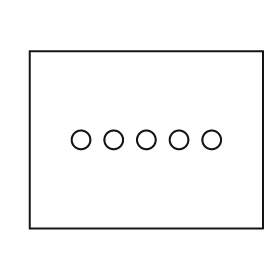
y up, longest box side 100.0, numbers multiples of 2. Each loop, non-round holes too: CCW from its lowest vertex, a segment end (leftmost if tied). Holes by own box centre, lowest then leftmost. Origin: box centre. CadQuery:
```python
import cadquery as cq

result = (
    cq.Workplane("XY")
    .moveTo(-50.0, -38.0)
    .lineTo(50.0, -38.0)
    .lineTo(50.0, 38.0)
    .lineTo(-50.0, 38.0)
    .close()
    .moveTo(-28.0, 0.0)
    .circle(4.0)
    .moveTo(-14.0, 0.0)
    .circle(4.0)
    .moveTo(0.0, 0.0)
    .circle(4.0)
    .moveTo(14.0, 0.0)
    .circle(4.0)
    .moveTo(28.0, 0.0)
    .circle(4.0)
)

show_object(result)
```